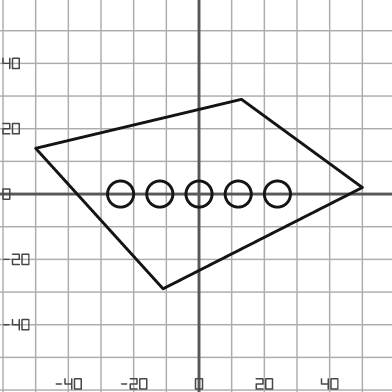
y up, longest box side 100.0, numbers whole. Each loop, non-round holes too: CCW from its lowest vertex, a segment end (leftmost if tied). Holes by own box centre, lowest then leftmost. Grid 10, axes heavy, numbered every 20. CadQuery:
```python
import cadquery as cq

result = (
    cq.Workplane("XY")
    .moveTo(-11.0, -29.0)
    .lineTo(50.0, 2.0)
    .lineTo(13.0, 29.0)
    .lineTo(-50.0, 14.0)
    .close()
    .moveTo(-24.0, 0.0)
    .circle(4.0)
    .moveTo(-12.0, 0.0)
    .circle(4.0)
    .moveTo(0.0, 0.0)
    .circle(4.0)
    .moveTo(12.0, 0.0)
    .circle(4.0)
    .moveTo(24.0, 0.0)
    .circle(4.0)
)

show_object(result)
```